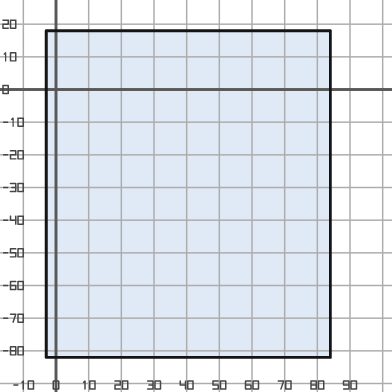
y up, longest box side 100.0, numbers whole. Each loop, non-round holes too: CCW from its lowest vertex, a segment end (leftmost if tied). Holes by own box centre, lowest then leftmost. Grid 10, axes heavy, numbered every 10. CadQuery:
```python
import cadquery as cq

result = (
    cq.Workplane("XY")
    .moveTo(-3.0, -82.0)
    .lineTo(84.0, -82.0)
    .lineTo(84.0, 18.0)
    .lineTo(-3.0, 18.0)
    .close()
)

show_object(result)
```